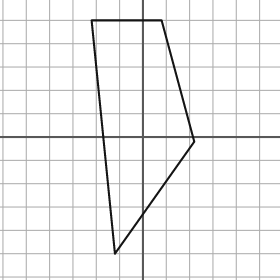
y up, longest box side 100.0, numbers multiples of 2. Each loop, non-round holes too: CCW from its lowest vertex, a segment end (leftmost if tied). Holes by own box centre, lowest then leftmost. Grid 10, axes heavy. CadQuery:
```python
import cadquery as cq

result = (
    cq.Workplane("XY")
    .moveTo(-12.0, -50.0)
    .lineTo(22.0, -2.0)
    .lineTo(8.0, 50.0)
    .lineTo(-22.0, 50.0)
    .close()
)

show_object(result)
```